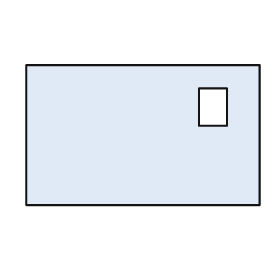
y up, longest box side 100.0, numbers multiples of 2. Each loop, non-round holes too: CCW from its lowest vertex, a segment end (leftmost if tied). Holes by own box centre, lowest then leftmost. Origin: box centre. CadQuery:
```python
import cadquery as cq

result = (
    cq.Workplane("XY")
    .moveTo(-50.0, -30.0)
    .lineTo(50.0, -30.0)
    .lineTo(50.0, 30.0)
    .lineTo(-50.0, 30.0)
    .close()
    .moveTo(24.0, 4.0)
    .lineTo(36.0, 4.0)
    .lineTo(36.0, 20.0)
    .lineTo(24.0, 20.0)
    .close()
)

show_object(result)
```